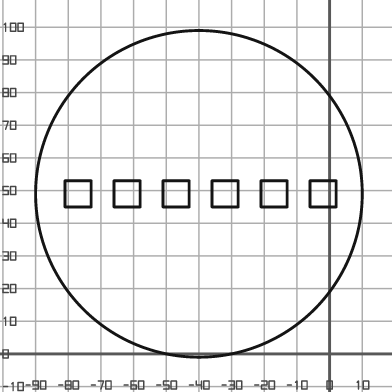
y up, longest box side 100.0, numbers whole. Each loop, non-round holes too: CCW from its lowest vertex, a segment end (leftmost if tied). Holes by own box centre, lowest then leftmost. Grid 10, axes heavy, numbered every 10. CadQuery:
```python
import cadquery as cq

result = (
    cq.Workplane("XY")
    .moveTo(-40.0, 49.0)
    .circle(50.0)
    .moveTo(-81.0, 45.0)
    .lineTo(-73.0, 45.0)
    .lineTo(-73.0, 53.0)
    .lineTo(-81.0, 53.0)
    .close()
    .moveTo(-66.0, 45.0)
    .lineTo(-58.0, 45.0)
    .lineTo(-58.0, 53.0)
    .lineTo(-66.0, 53.0)
    .close()
    .moveTo(-51.0, 45.0)
    .lineTo(-43.0, 45.0)
    .lineTo(-43.0, 53.0)
    .lineTo(-51.0, 53.0)
    .close()
    .moveTo(-36.0, 45.0)
    .lineTo(-28.0, 45.0)
    .lineTo(-28.0, 53.0)
    .lineTo(-36.0, 53.0)
    .close()
    .moveTo(-21.0, 45.0)
    .lineTo(-13.0, 45.0)
    .lineTo(-13.0, 53.0)
    .lineTo(-21.0, 53.0)
    .close()
    .moveTo(-6.0, 45.0)
    .lineTo(2.0, 45.0)
    .lineTo(2.0, 53.0)
    .lineTo(-6.0, 53.0)
    .close()
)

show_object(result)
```